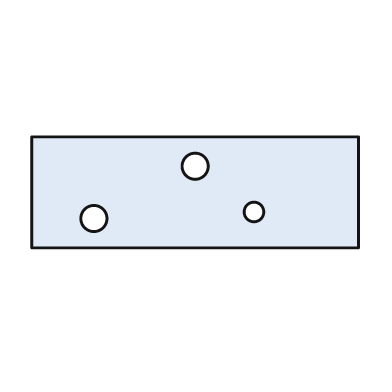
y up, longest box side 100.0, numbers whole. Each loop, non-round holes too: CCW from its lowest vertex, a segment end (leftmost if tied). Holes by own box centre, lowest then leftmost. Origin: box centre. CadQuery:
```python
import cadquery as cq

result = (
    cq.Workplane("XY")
    .moveTo(-50.0, -17.0)
    .lineTo(50.0, -17.0)
    .lineTo(50.0, 17.0)
    .lineTo(-50.0, 17.0)
    .close()
    .moveTo(-31.0, -8.0)
    .circle(4.0)
    .moveTo(18.0, -6.0)
    .circle(3.0)
    .moveTo(0.0, 8.0)
    .circle(4.0)
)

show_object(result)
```